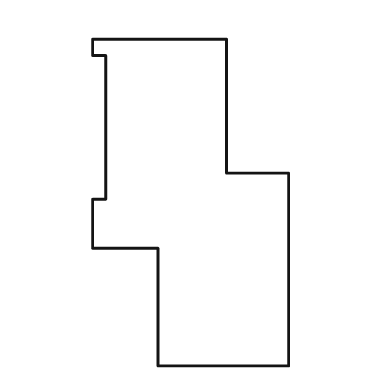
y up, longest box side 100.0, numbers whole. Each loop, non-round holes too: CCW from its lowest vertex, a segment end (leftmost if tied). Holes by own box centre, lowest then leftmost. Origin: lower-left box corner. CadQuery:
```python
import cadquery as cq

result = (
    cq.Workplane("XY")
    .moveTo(20.0, 0.0)
    .lineTo(60.0, 0.0)
    .lineTo(60.0, 59.0)
    .lineTo(41.0, 59.0)
    .lineTo(41.0, 100.0)
    .lineTo(0.0, 100.0)
    .lineTo(0.0, 95.0)
    .lineTo(4.0, 95.0)
    .lineTo(4.0, 51.0)
    .lineTo(0.0, 51.0)
    .lineTo(0.0, 36.0)
    .lineTo(20.0, 36.0)
    .close()
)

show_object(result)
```